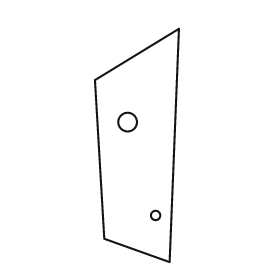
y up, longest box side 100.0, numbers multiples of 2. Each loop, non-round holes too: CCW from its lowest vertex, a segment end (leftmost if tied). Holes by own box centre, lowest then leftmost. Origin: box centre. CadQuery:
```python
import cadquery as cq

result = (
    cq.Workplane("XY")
    .moveTo(14.0, -50.0)
    .lineTo(18.0, 50.0)
    .lineTo(-18.0, 28.0)
    .lineTo(-14.0, -40.0)
    .close()
    .moveTo(8.0, -30.0)
    .circle(2.0)
    .moveTo(-4.0, 10.0)
    .circle(4.0)
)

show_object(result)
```